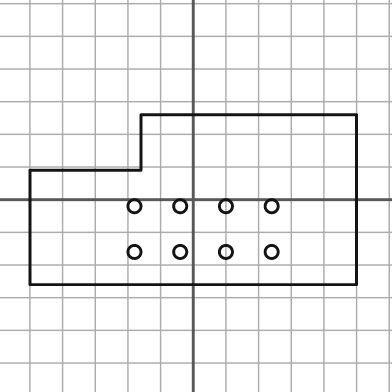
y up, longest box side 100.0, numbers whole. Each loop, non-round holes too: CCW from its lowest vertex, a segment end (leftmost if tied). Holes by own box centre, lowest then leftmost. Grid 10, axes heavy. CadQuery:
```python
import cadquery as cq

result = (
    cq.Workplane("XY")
    .moveTo(-50.0, -26.0)
    .lineTo(50.0, -26.0)
    .lineTo(50.0, 26.0)
    .lineTo(-16.0, 26.0)
    .lineTo(-16.0, 9.0)
    .lineTo(-50.0, 9.0)
    .close()
    .moveTo(-18.0, -16.0)
    .circle(2.0)
    .moveTo(-4.0, -16.0)
    .circle(2.0)
    .moveTo(10.0, -16.0)
    .circle(2.0)
    .moveTo(24.0, -16.0)
    .circle(2.0)
    .moveTo(-18.0, -2.0)
    .circle(2.0)
    .moveTo(-4.0, -2.0)
    .circle(2.0)
    .moveTo(10.0, -2.0)
    .circle(2.0)
    .moveTo(24.0, -2.0)
    .circle(2.0)
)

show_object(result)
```